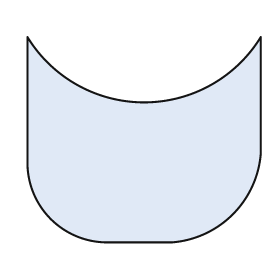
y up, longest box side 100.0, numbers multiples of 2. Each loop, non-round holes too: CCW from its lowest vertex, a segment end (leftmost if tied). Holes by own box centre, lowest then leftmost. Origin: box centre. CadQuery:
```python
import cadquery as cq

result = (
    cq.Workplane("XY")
    .moveTo(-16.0, -44.0)
    .lineTo(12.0, -44.0)
    .threePointArc((38.0, -32.0), (50.0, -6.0))
    .lineTo(50.0, 44.0)
    .threePointArc((0.0, 16.0), (-50.0, 44.0))
    .lineTo(-50.0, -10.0)
    .threePointArc((-40.0, -34.0), (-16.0, -44.0))
    .close()
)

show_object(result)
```